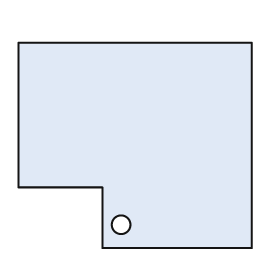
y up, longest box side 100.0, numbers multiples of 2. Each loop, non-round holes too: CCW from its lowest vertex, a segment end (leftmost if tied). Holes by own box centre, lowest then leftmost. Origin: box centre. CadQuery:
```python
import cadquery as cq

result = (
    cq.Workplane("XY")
    .moveTo(-14.0, -44.0)
    .lineTo(50.0, -44.0)
    .lineTo(50.0, 44.0)
    .lineTo(-50.0, 44.0)
    .lineTo(-50.0, -18.0)
    .lineTo(-14.0, -18.0)
    .close()
    .moveTo(-6.0, -34.0)
    .circle(4.0)
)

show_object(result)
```